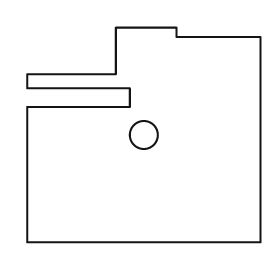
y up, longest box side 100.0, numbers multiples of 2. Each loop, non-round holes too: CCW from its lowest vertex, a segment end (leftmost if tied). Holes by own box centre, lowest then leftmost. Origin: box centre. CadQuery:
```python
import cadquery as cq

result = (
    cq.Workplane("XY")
    .moveTo(-50.0, -46.0)
    .lineTo(50.0, -46.0)
    .lineTo(50.0, 42.0)
    .lineTo(14.0, 42.0)
    .lineTo(14.0, 46.0)
    .lineTo(-12.0, 46.0)
    .lineTo(-12.0, 26.0)
    .lineTo(-50.0, 26.0)
    .lineTo(-50.0, 20.0)
    .lineTo(-6.0, 20.0)
    .lineTo(-6.0, 12.0)
    .lineTo(-50.0, 12.0)
    .close()
    .moveTo(0.0, 0.0)
    .circle(6.0)
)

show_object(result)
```